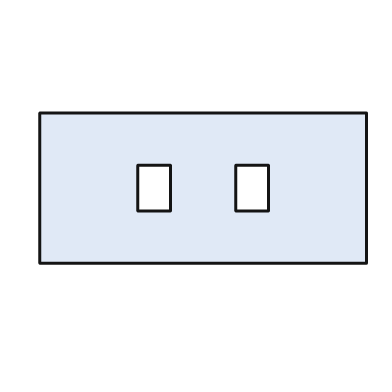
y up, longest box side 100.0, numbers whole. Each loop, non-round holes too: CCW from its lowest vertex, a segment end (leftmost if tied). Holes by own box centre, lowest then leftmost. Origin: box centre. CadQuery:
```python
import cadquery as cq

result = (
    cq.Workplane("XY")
    .moveTo(-50.0, -23.0)
    .lineTo(50.0, -23.0)
    .lineTo(50.0, 23.0)
    .lineTo(-50.0, 23.0)
    .close()
    .moveTo(-20.0, -7.0)
    .lineTo(-10.0, -7.0)
    .lineTo(-10.0, 7.0)
    .lineTo(-20.0, 7.0)
    .close()
    .moveTo(10.0, -7.0)
    .lineTo(20.0, -7.0)
    .lineTo(20.0, 7.0)
    .lineTo(10.0, 7.0)
    .close()
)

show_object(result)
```